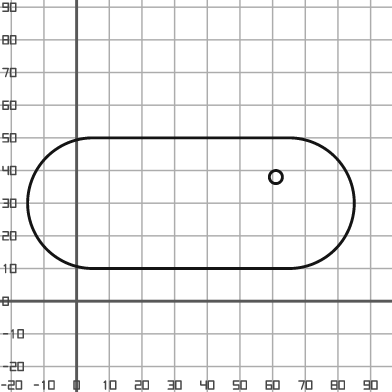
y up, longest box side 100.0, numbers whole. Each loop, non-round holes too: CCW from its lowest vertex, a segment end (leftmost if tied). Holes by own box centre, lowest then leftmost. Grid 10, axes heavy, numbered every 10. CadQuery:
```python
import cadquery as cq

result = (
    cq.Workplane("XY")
    .moveTo(5.0, 10.0)
    .lineTo(65.0, 10.0)
    .threePointArc((85.0, 30.0), (65.0, 50.0))
    .lineTo(5.0, 50.0)
    .threePointArc((-15.0, 30.0), (5.0, 10.0))
    .close()
    .moveTo(61.0, 38.0)
    .circle(2.0)
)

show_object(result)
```